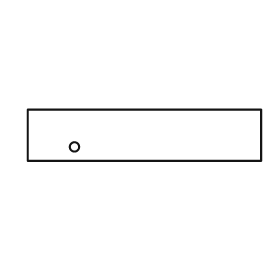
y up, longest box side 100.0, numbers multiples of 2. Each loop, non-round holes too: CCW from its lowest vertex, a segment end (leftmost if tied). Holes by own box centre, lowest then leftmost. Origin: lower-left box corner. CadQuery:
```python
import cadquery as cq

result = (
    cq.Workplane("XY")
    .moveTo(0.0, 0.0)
    .lineTo(100.0, 0.0)
    .lineTo(100.0, 22.0)
    .lineTo(0.0, 22.0)
    .close()
    .moveTo(20.0, 6.0)
    .circle(2.0)
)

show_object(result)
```